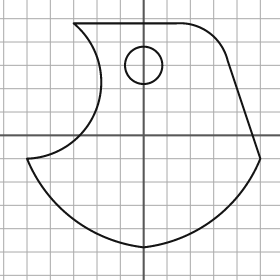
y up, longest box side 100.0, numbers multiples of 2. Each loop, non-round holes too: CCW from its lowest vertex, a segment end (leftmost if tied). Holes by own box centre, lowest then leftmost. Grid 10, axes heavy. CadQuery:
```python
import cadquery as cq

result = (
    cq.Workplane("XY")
    .moveTo(0.0, -48.0)
    .threePointArc((30.0, -36.0), (50.0, -10.0))
    .lineTo(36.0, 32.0)
    .threePointArc((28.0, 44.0), (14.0, 48.0))
    .lineTo(-30.0, 48.0)
    .threePointArc((-20.0, 12.0), (-50.0, -10.0))
    .threePointArc((-30.0, -36.0), (0.0, -48.0))
    .close()
    .moveTo(0.0, 30.0)
    .circle(8.0)
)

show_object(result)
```